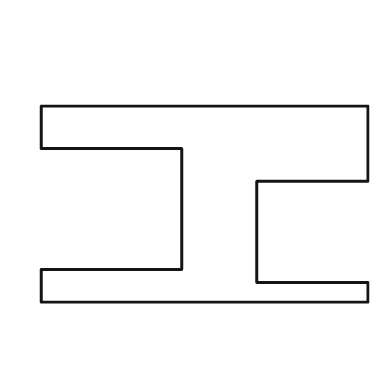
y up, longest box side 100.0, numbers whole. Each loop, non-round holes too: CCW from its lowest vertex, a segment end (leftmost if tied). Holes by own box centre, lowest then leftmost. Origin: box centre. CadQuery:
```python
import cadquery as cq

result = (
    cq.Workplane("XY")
    .moveTo(-50.0, -30.0)
    .lineTo(50.0, -30.0)
    .lineTo(50.0, -24.0)
    .lineTo(16.0, -24.0)
    .lineTo(16.0, 7.0)
    .lineTo(50.0, 7.0)
    .lineTo(50.0, 30.0)
    .lineTo(-50.0, 30.0)
    .lineTo(-50.0, 17.0)
    .lineTo(-7.0, 17.0)
    .lineTo(-7.0, -20.0)
    .lineTo(-50.0, -20.0)
    .close()
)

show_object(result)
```